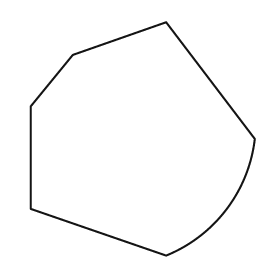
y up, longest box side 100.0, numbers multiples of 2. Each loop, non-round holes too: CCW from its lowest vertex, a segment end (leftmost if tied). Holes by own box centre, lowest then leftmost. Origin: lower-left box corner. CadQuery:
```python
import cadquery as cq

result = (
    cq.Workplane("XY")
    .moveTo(58.0, 0.0)
    .threePointArc((84.0, 20.0), (96.0, 50.0))
    .lineTo(58.0, 100.0)
    .lineTo(18.0, 86.0)
    .lineTo(0.0, 64.0)
    .lineTo(0.0, 20.0)
    .close()
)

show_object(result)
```